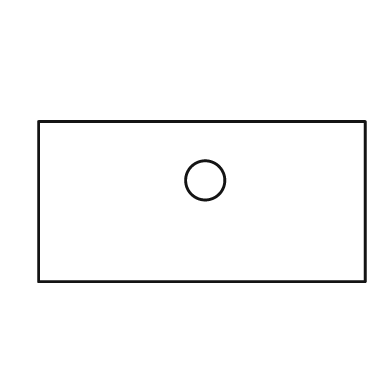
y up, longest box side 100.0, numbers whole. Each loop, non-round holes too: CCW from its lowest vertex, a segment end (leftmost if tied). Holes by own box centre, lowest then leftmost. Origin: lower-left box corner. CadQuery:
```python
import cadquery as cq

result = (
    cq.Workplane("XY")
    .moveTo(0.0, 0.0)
    .lineTo(100.0, 0.0)
    .lineTo(100.0, 49.0)
    .lineTo(0.0, 49.0)
    .close()
    .moveTo(51.0, 31.0)
    .circle(6.0)
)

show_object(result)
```